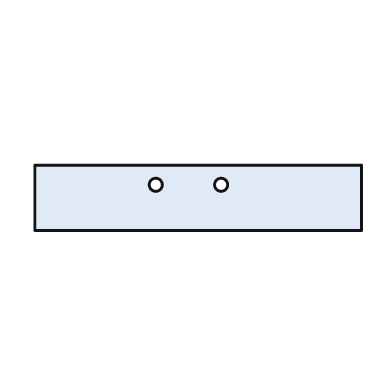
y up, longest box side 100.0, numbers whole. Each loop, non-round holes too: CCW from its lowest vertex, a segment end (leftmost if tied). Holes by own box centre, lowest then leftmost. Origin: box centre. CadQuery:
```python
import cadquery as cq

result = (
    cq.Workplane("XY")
    .moveTo(-50.0, -10.0)
    .lineTo(50.0, -10.0)
    .lineTo(50.0, 10.0)
    .lineTo(-50.0, 10.0)
    .close()
    .moveTo(-13.0, 4.0)
    .circle(2.0)
    .moveTo(7.0, 4.0)
    .circle(2.0)
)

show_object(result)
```